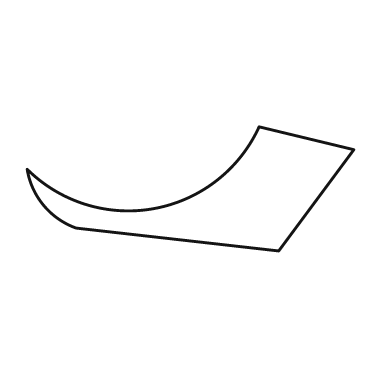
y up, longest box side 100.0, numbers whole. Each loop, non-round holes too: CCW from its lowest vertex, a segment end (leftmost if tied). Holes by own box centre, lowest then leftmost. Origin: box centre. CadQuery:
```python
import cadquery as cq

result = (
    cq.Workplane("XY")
    .moveTo(27.0, -19.0)
    .lineTo(50.0, 12.0)
    .lineTo(21.0, 19.0)
    .threePointArc((-11.0, -6.0), (-50.0, 6.0))
    .threePointArc((-45.0, -5.0), (-35.0, -12.0))
    .close()
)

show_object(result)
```